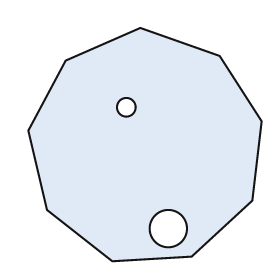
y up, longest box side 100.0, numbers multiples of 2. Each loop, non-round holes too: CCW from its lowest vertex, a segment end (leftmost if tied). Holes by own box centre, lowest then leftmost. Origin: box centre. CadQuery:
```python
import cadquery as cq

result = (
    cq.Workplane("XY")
    .moveTo(-14.0, -50.0)
    .lineTo(20.0, -48.0)
    .lineTo(46.0, -24.0)
    .lineTo(50.0, 10.0)
    .lineTo(32.0, 38.0)
    .lineTo(-2.0, 50.0)
    .lineTo(-34.0, 36.0)
    .lineTo(-50.0, 6.0)
    .lineTo(-42.0, -28.0)
    .close()
    .moveTo(10.0, -36.0)
    .circle(8.0)
    .moveTo(-8.0, 16.0)
    .circle(4.0)
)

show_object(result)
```